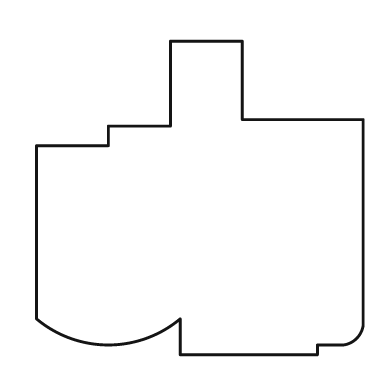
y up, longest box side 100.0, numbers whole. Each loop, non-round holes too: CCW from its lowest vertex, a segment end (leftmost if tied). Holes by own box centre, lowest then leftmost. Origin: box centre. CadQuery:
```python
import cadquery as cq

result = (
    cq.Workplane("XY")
    .moveTo(-6.0, -48.0)
    .lineTo(36.0, -48.0)
    .lineTo(36.0, -45.0)
    .lineTo(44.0, -45.0)
    .threePointArc((48.0, -43.0), (50.0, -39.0))
    .lineTo(50.0, 24.0)
    .lineTo(13.0, 24.0)
    .lineTo(13.0, 48.0)
    .lineTo(-9.0, 48.0)
    .lineTo(-9.0, 22.0)
    .lineTo(-28.0, 22.0)
    .lineTo(-28.0, 16.0)
    .lineTo(-50.0, 16.0)
    .lineTo(-50.0, -37.0)
    .threePointArc((-28.0, -45.0), (-6.0, -37.0))
    .close()
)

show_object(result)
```